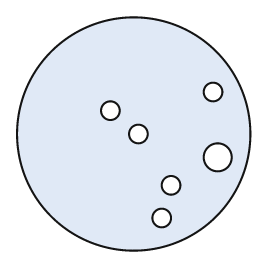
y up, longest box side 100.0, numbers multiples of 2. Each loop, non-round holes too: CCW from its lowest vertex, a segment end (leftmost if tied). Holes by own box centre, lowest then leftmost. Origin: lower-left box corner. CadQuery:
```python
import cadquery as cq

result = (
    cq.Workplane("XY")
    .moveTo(50.0, 50.0)
    .circle(50.0)
    .moveTo(62.0, 14.0)
    .circle(4.0)
    .moveTo(66.0, 28.0)
    .circle(4.0)
    .moveTo(86.0, 40.0)
    .circle(6.0)
    .moveTo(52.0, 50.0)
    .circle(4.0)
    .moveTo(40.0, 60.0)
    .circle(4.0)
    .moveTo(84.0, 68.0)
    .circle(4.0)
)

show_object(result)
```